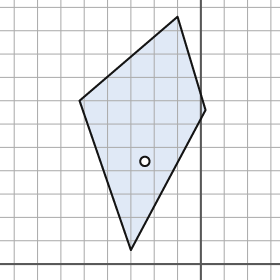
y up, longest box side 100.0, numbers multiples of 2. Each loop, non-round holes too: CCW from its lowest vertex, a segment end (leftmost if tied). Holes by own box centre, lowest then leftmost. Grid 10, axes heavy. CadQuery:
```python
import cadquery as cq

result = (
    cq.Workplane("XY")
    .moveTo(-30.0, 6.0)
    .lineTo(2.0, 66.0)
    .lineTo(-10.0, 106.0)
    .lineTo(-52.0, 70.0)
    .close()
    .moveTo(-24.0, 44.0)
    .circle(2.0)
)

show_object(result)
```